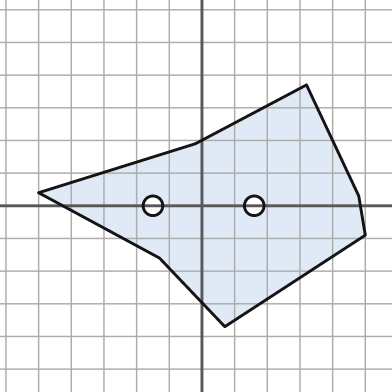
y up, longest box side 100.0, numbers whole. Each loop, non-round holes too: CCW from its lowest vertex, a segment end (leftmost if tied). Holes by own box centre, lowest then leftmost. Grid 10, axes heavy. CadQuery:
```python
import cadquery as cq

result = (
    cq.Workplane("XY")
    .moveTo(7.0, -37.0)
    .lineTo(50.0, -9.0)
    .lineTo(48.0, 3.0)
    .lineTo(32.0, 37.0)
    .lineTo(-2.0, 19.0)
    .lineTo(-50.0, 4.0)
    .lineTo(-13.0, -16.0)
    .close()
    .moveTo(-15.0, 0.0)
    .circle(3.0)
    .moveTo(16.0, 0.0)
    .circle(3.0)
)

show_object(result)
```